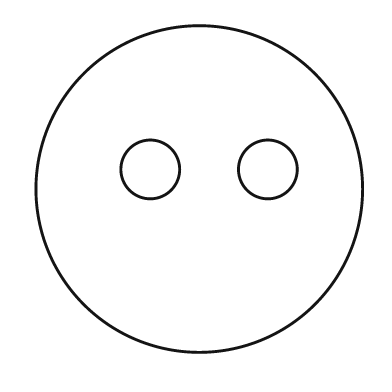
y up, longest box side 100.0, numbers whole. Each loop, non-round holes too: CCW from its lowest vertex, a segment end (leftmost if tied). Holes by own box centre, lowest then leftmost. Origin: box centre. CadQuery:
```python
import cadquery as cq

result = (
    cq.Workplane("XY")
    .moveTo(0.0, 0.0)
    .circle(50.0)
    .moveTo(-15.0, 6.0)
    .circle(9.0)
    .moveTo(21.0, 6.0)
    .circle(9.0)
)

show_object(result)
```